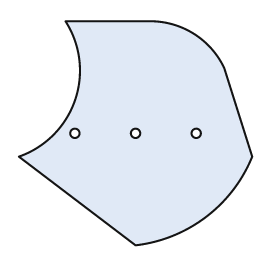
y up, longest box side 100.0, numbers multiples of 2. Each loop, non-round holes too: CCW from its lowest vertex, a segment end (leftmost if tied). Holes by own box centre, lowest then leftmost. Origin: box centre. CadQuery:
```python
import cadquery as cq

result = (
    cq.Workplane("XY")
    .moveTo(0.0, -48.0)
    .threePointArc((30.0, -36.0), (50.0, -10.0))
    .lineTo(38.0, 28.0)
    .threePointArc((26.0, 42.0), (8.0, 48.0))
    .lineTo(-30.0, 48.0)
    .threePointArc((-26.0, 14.0), (-50.0, -10.0))
    .close()
    .moveTo(-26.0, 0.0)
    .circle(2.0)
    .moveTo(0.0, 0.0)
    .circle(2.0)
    .moveTo(26.0, 0.0)
    .circle(2.0)
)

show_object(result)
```